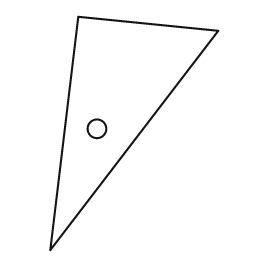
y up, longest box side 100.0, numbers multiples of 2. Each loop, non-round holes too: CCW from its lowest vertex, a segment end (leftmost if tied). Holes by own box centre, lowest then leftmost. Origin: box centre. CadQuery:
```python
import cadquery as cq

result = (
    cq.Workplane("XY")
    .moveTo(-36.0, -50.0)
    .lineTo(36.0, 44.0)
    .lineTo(-24.0, 50.0)
    .close()
    .moveTo(-16.0, 2.0)
    .circle(4.0)
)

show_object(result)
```